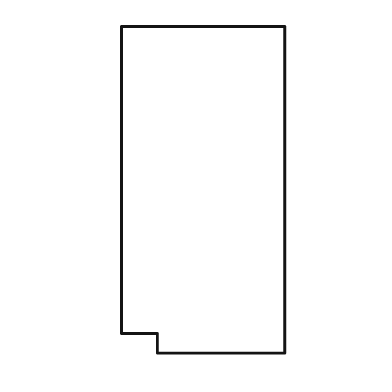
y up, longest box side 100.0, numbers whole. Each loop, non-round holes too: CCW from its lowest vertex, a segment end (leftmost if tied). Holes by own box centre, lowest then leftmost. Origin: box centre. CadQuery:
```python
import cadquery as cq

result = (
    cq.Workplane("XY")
    .moveTo(-14.0, -50.0)
    .lineTo(25.0, -50.0)
    .lineTo(25.0, 50.0)
    .lineTo(-25.0, 50.0)
    .lineTo(-25.0, -44.0)
    .lineTo(-14.0, -44.0)
    .close()
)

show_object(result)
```